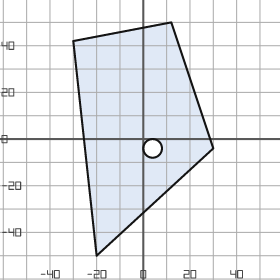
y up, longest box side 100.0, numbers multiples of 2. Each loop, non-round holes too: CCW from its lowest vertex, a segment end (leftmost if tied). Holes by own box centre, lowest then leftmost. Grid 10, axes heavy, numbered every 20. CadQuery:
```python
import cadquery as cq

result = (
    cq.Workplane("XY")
    .moveTo(-20.0, -50.0)
    .lineTo(30.0, -4.0)
    .lineTo(12.0, 50.0)
    .lineTo(-30.0, 42.0)
    .close()
    .moveTo(4.0, -4.0)
    .circle(4.0)
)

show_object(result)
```